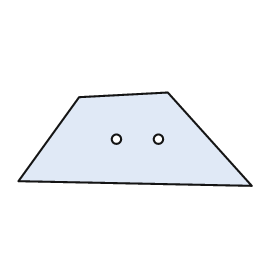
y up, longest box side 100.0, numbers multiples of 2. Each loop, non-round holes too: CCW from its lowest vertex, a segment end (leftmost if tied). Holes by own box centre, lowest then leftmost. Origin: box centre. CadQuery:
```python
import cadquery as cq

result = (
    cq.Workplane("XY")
    .moveTo(50.0, -20.0)
    .lineTo(14.0, 20.0)
    .lineTo(-24.0, 18.0)
    .lineTo(-50.0, -18.0)
    .close()
    .moveTo(-8.0, 0.0)
    .circle(2.0)
    .moveTo(10.0, 0.0)
    .circle(2.0)
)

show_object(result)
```